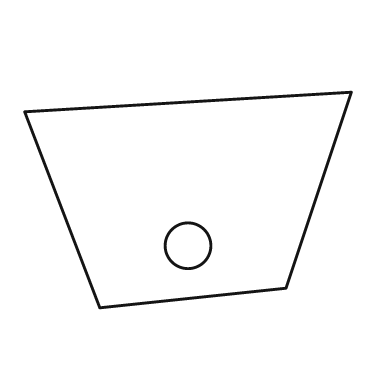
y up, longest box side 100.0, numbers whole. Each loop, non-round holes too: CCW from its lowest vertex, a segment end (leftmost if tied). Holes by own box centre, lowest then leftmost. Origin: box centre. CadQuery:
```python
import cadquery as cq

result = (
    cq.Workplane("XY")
    .moveTo(-27.0, -33.0)
    .lineTo(30.0, -27.0)
    .lineTo(50.0, 33.0)
    .lineTo(-50.0, 27.0)
    .close()
    .moveTo(0.0, -14.0)
    .circle(7.0)
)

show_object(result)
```